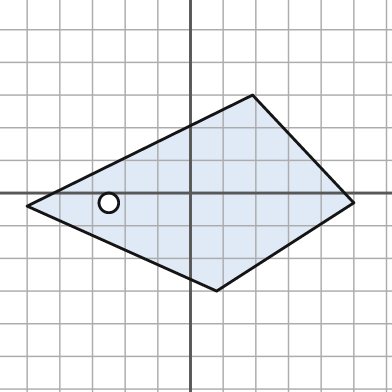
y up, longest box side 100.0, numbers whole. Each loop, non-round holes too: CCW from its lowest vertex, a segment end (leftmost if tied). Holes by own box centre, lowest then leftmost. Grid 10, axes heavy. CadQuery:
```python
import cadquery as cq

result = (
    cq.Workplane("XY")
    .moveTo(8.0, -30.0)
    .lineTo(50.0, -3.0)
    .lineTo(19.0, 30.0)
    .lineTo(-50.0, -4.0)
    .close()
    .moveTo(-25.0, -3.0)
    .circle(3.0)
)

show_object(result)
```